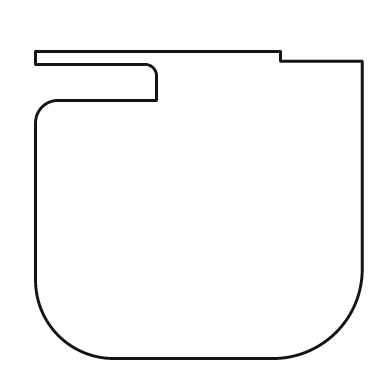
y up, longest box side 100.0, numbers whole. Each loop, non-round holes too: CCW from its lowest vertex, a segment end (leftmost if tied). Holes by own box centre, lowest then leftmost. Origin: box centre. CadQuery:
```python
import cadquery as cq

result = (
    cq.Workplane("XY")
    .moveTo(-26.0, -47.0)
    .lineTo(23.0, -47.0)
    .threePointArc((42.0, -39.0), (50.0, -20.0))
    .lineTo(50.0, 44.0)
    .lineTo(25.0, 44.0)
    .lineTo(25.0, 47.0)
    .lineTo(-50.0, 47.0)
    .lineTo(-50.0, 43.0)
    .lineTo(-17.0, 43.0)
    .threePointArc((-14.0, 42.0), (-13.0, 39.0))
    .lineTo(-13.0, 32.0)
    .lineTo(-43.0, 32.0)
    .threePointArc((-48.0, 30.0), (-50.0, 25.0))
    .lineTo(-50.0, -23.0)
    .threePointArc((-43.0, -40.0), (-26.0, -47.0))
    .close()
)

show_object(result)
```